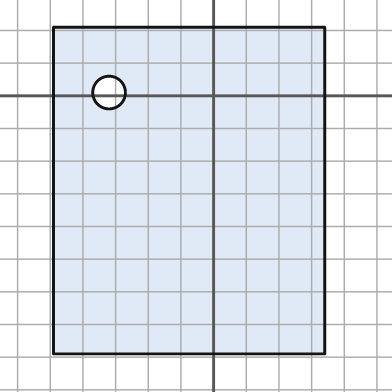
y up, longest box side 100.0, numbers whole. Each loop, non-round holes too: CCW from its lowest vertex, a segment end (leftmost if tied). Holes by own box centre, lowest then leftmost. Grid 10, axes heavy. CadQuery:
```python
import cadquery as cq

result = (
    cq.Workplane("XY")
    .moveTo(-49.0, -79.0)
    .lineTo(34.0, -79.0)
    .lineTo(34.0, 21.0)
    .lineTo(-49.0, 21.0)
    .close()
    .moveTo(-32.0, 1.0)
    .circle(5.0)
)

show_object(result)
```